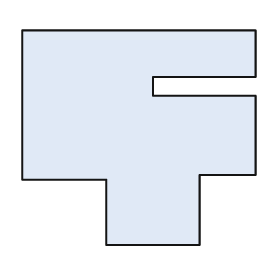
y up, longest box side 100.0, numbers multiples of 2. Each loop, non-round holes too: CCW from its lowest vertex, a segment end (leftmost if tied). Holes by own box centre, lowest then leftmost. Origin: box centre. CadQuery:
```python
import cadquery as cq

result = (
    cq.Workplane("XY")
    .moveTo(-14.0, -46.0)
    .lineTo(26.0, -46.0)
    .lineTo(26.0, -16.0)
    .lineTo(50.0, -16.0)
    .lineTo(50.0, 18.0)
    .lineTo(6.0, 18.0)
    .lineTo(6.0, 26.0)
    .lineTo(50.0, 26.0)
    .lineTo(50.0, 46.0)
    .lineTo(-50.0, 46.0)
    .lineTo(-50.0, -18.0)
    .lineTo(-14.0, -18.0)
    .close()
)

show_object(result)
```